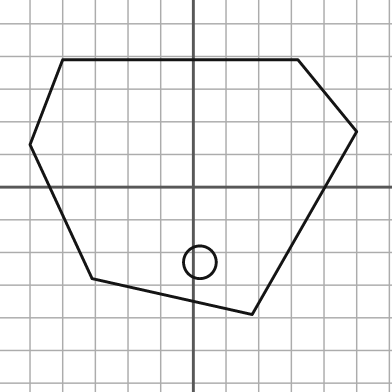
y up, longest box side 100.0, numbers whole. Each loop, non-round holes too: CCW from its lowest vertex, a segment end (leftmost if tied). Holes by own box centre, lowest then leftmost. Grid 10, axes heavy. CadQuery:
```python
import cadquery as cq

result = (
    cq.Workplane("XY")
    .moveTo(18.0, -39.0)
    .lineTo(50.0, 17.0)
    .lineTo(32.0, 39.0)
    .lineTo(-40.0, 39.0)
    .lineTo(-50.0, 13.0)
    .lineTo(-31.0, -28.0)
    .close()
    .moveTo(2.0, -23.0)
    .circle(5.0)
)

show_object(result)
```